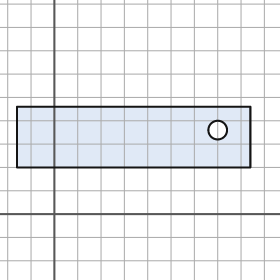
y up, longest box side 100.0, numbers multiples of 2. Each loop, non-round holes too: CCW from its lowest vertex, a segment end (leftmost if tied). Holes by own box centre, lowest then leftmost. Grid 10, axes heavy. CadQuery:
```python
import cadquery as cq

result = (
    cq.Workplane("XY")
    .moveTo(-16.0, 20.0)
    .lineTo(84.0, 20.0)
    .lineTo(84.0, 46.0)
    .lineTo(-16.0, 46.0)
    .close()
    .moveTo(70.0, 36.0)
    .circle(4.0)
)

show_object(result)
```